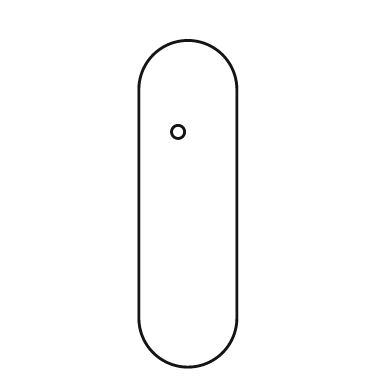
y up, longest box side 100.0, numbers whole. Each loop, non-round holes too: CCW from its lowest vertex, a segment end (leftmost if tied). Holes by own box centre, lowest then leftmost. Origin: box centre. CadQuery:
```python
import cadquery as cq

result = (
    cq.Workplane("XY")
    .moveTo(-15.0, -35.0)
    .threePointArc((0.0, -50.0), (15.0, -35.0))
    .lineTo(15.0, 35.0)
    .threePointArc((0.0, 50.0), (-15.0, 35.0))
    .close()
    .moveTo(-3.0, 22.0)
    .circle(2.0)
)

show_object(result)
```